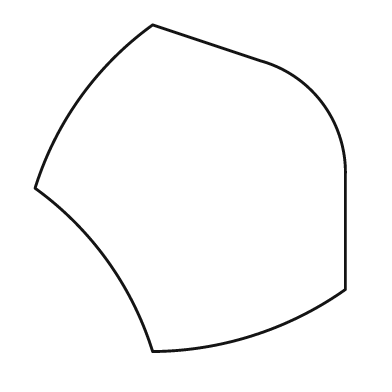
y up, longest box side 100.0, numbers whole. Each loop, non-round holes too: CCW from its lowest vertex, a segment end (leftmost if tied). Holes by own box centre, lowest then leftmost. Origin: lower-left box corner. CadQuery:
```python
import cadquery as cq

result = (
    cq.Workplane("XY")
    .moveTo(36.0, 0.0)
    .threePointArc((67.0, 5.0), (95.0, 19.0))
    .lineTo(95.0, 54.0)
    .threePointArc((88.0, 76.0), (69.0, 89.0))
    .lineTo(36.0, 100.0)
    .threePointArc((14.0, 78.0), (0.0, 50.0))
    .threePointArc((22.0, 28.0), (36.0, 0.0))
    .close()
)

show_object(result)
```